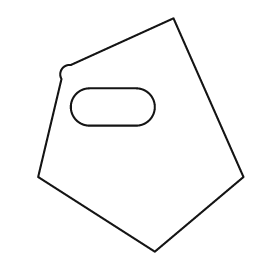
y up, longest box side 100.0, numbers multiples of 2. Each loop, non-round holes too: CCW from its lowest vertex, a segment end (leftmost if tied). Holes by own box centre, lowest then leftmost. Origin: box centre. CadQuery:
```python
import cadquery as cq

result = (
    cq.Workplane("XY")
    .moveTo(6.0, -50.0)
    .lineTo(44.0, -18.0)
    .lineTo(14.0, 50.0)
    .lineTo(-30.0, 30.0)
    .threePointArc((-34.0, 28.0), (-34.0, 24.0))
    .lineTo(-44.0, -18.0)
    .close()
    .moveTo(-22.0, 4.0)
    .lineTo(-2.0, 4.0)
    .threePointArc((6.0, 12.0), (-2.0, 20.0))
    .lineTo(-22.0, 20.0)
    .threePointArc((-30.0, 12.0), (-22.0, 4.0))
    .close()
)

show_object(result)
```